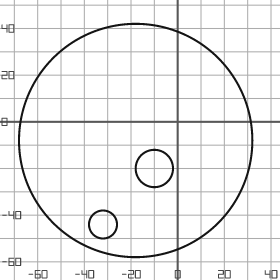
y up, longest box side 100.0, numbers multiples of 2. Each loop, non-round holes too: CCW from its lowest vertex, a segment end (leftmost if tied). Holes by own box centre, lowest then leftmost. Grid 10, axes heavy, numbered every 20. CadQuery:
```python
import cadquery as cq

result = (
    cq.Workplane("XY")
    .moveTo(-18.0, -8.0)
    .circle(50.0)
    .moveTo(-32.0, -44.0)
    .circle(6.0)
    .moveTo(-10.0, -20.0)
    .circle(8.0)
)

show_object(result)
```